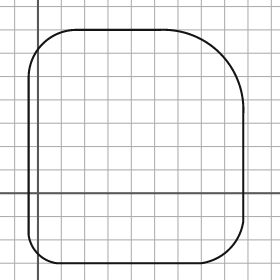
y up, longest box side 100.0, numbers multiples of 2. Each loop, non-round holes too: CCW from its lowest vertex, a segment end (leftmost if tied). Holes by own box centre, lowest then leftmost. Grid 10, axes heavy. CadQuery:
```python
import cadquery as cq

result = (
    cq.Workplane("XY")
    .moveTo(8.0, -30.0)
    .lineTo(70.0, -30.0)
    .threePointArc((82.0, -24.0), (88.0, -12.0))
    .lineTo(88.0, 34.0)
    .threePointArc((78.0, 60.0), (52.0, 70.0))
    .lineTo(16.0, 70.0)
    .threePointArc((2.0, 64.0), (-4.0, 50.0))
    .lineTo(-4.0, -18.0)
    .threePointArc((0.0, -26.0), (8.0, -30.0))
    .close()
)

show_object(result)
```